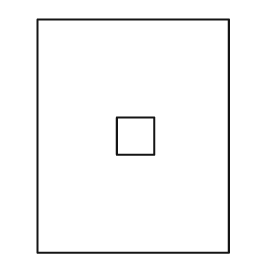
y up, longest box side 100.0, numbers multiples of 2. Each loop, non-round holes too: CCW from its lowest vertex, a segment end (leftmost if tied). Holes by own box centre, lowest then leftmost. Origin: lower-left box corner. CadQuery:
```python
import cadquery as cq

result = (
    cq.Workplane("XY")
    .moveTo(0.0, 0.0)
    .lineTo(82.0, 0.0)
    .lineTo(82.0, 100.0)
    .lineTo(0.0, 100.0)
    .close()
    .moveTo(34.0, 42.0)
    .lineTo(50.0, 42.0)
    .lineTo(50.0, 58.0)
    .lineTo(34.0, 58.0)
    .close()
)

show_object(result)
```